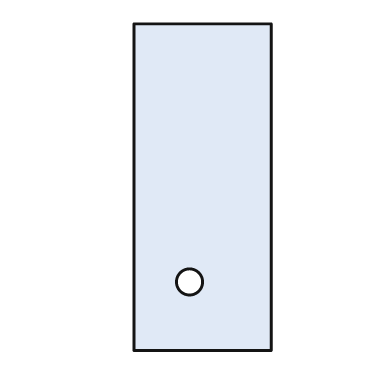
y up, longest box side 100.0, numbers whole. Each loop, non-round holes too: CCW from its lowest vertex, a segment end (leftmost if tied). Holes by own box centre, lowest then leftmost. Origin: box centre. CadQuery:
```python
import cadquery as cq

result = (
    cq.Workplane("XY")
    .moveTo(-21.0, -50.0)
    .lineTo(21.0, -50.0)
    .lineTo(21.0, 50.0)
    .lineTo(-21.0, 50.0)
    .close()
    .moveTo(-4.0, -29.0)
    .circle(4.0)
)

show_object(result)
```